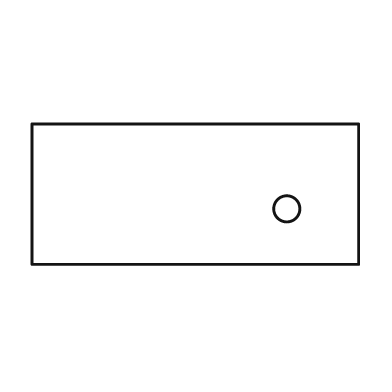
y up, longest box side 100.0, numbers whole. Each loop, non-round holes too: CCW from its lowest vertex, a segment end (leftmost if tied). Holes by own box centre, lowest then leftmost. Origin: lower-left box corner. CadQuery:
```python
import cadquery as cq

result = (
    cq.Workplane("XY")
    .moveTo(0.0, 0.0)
    .lineTo(100.0, 0.0)
    .lineTo(100.0, 43.0)
    .lineTo(0.0, 43.0)
    .close()
    .moveTo(78.0, 17.0)
    .circle(4.0)
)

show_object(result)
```